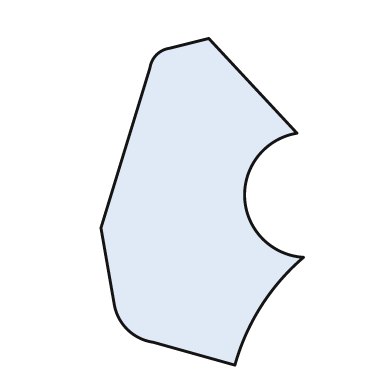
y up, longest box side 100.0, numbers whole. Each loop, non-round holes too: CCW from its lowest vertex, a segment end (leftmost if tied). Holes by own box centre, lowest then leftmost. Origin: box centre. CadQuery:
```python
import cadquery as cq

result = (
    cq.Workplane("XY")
    .moveTo(10.0, -50.0)
    .threePointArc((18.0, -32.0), (31.0, -17.0))
    .threePointArc((13.0, 1.0), (29.0, 21.0))
    .lineTo(2.0, 50.0)
    .lineTo(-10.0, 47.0)
    .threePointArc((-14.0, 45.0), (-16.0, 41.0))
    .lineTo(-31.0, -8.0)
    .lineTo(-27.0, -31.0)
    .threePointArc((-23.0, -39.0), (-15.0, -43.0))
    .close()
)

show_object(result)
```